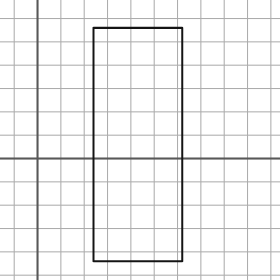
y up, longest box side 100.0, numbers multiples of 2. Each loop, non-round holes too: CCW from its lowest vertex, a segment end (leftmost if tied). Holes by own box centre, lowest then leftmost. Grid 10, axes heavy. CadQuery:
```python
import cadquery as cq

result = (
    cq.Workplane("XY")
    .moveTo(24.0, -44.0)
    .lineTo(62.0, -44.0)
    .lineTo(62.0, 56.0)
    .lineTo(24.0, 56.0)
    .close()
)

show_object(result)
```